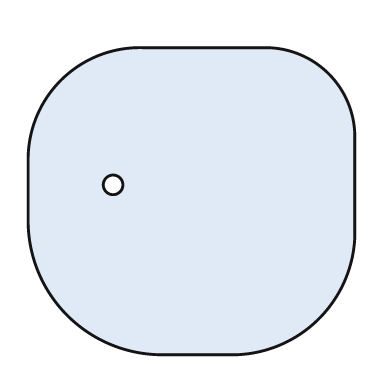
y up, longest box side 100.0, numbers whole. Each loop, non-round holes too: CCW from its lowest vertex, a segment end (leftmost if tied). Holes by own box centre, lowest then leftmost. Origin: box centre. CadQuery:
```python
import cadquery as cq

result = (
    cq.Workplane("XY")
    .moveTo(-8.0, -47.0)
    .lineTo(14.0, -47.0)
    .threePointArc((39.0, -36.0), (50.0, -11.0))
    .lineTo(50.0, 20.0)
    .threePointArc((42.0, 39.0), (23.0, 47.0))
    .lineTo(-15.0, 47.0)
    .threePointArc((-40.0, 37.0), (-50.0, 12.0))
    .lineTo(-50.0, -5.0)
    .threePointArc((-38.0, -35.0), (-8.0, -47.0))
    .close()
    .moveTo(-24.0, 5.0)
    .circle(3.0)
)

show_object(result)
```